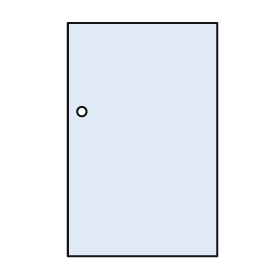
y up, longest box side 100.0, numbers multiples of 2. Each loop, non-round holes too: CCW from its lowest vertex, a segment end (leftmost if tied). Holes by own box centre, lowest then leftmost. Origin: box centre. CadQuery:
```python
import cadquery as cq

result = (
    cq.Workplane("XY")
    .moveTo(-32.0, -50.0)
    .lineTo(32.0, -50.0)
    .lineTo(32.0, 50.0)
    .lineTo(-32.0, 50.0)
    .close()
    .moveTo(-26.0, 12.0)
    .circle(2.0)
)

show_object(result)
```